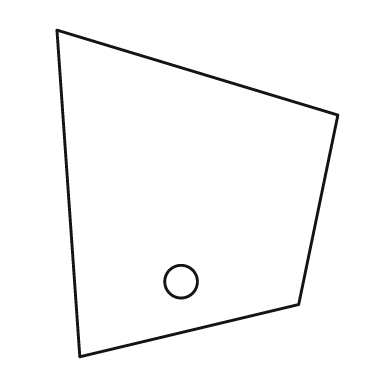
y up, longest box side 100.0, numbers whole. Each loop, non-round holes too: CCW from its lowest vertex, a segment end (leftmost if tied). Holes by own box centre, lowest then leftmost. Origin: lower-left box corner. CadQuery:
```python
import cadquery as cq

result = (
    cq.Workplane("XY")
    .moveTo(7.0, 0.0)
    .lineTo(74.0, 16.0)
    .lineTo(86.0, 74.0)
    .lineTo(0.0, 100.0)
    .close()
    .moveTo(38.0, 23.0)
    .circle(5.0)
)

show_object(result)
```